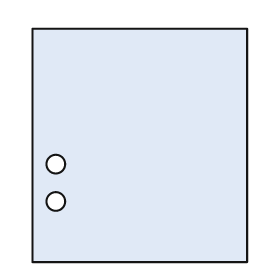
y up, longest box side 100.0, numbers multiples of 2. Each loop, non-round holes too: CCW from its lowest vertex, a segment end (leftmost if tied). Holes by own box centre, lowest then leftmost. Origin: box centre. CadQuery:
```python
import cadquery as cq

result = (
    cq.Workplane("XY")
    .moveTo(-46.0, -50.0)
    .lineTo(46.0, -50.0)
    .lineTo(46.0, 50.0)
    .lineTo(-46.0, 50.0)
    .close()
    .moveTo(-36.0, -24.0)
    .circle(4.0)
    .moveTo(-36.0, -8.0)
    .circle(4.0)
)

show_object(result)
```